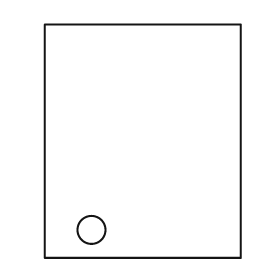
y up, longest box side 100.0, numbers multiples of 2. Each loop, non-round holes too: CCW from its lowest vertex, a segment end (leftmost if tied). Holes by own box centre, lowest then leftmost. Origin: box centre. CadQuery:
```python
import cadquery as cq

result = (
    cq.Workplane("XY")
    .moveTo(-42.0, -50.0)
    .lineTo(42.0, -50.0)
    .lineTo(42.0, 50.0)
    .lineTo(-42.0, 50.0)
    .close()
    .moveTo(-22.0, -38.0)
    .circle(6.0)
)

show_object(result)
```